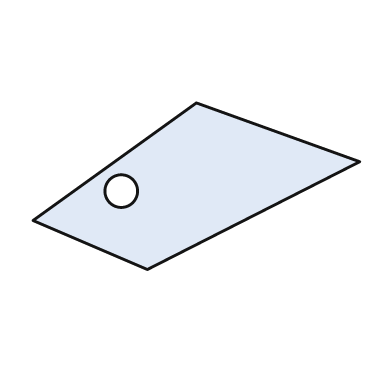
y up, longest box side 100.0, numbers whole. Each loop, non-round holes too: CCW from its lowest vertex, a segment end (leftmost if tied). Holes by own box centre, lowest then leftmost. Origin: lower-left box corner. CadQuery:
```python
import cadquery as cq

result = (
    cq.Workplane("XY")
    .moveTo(35.0, 0.0)
    .lineTo(100.0, 33.0)
    .lineTo(50.0, 51.0)
    .lineTo(0.0, 15.0)
    .close()
    .moveTo(27.0, 24.0)
    .circle(5.0)
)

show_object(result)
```